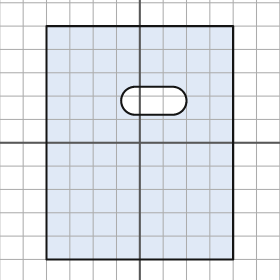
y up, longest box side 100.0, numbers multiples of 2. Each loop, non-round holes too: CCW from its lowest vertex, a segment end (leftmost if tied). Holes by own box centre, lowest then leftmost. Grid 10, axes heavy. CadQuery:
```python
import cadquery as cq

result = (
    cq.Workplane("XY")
    .moveTo(-40.0, -50.0)
    .lineTo(40.0, -50.0)
    .lineTo(40.0, 50.0)
    .lineTo(-40.0, 50.0)
    .close()
    .moveTo(-2.0, 12.0)
    .lineTo(14.0, 12.0)
    .threePointArc((20.0, 18.0), (14.0, 24.0))
    .lineTo(-2.0, 24.0)
    .threePointArc((-8.0, 18.0), (-2.0, 12.0))
    .close()
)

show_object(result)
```